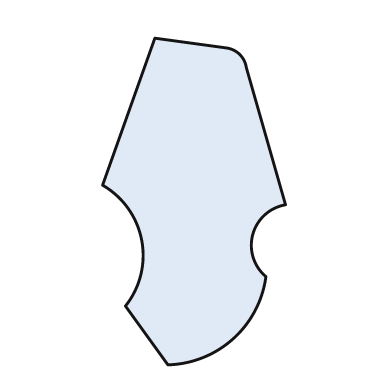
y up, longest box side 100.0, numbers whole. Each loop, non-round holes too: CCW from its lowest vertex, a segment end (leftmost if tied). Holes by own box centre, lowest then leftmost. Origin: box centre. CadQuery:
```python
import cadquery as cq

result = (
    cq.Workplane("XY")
    .moveTo(-8.0, -50.0)
    .threePointArc((12.0, -42.0), (22.0, -23.0))
    .threePointArc((18.0, -10.0), (28.0, -1.0))
    .lineTo(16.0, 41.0)
    .threePointArc((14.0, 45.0), (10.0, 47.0))
    .lineTo(-12.0, 50.0)
    .lineTo(-28.0, 5.0)
    .threePointArc((-16.0, -12.0), (-21.0, -32.0))
    .close()
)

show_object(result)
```